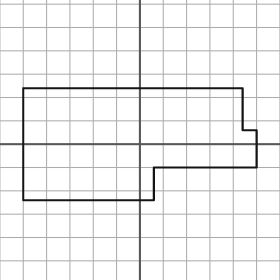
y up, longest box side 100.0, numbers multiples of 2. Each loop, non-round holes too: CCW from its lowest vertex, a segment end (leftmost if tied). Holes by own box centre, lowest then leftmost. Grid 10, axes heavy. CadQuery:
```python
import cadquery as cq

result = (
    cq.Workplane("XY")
    .moveTo(-50.0, -24.0)
    .lineTo(6.0, -24.0)
    .lineTo(6.0, -10.0)
    .lineTo(50.0, -10.0)
    .lineTo(50.0, 6.0)
    .lineTo(44.0, 6.0)
    .lineTo(44.0, 24.0)
    .lineTo(-50.0, 24.0)
    .close()
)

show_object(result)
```